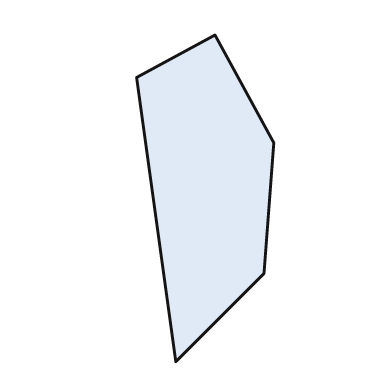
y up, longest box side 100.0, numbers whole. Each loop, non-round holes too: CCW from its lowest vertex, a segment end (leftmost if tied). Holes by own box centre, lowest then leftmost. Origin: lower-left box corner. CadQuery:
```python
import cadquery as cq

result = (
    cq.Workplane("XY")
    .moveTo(12.0, 0.0)
    .lineTo(39.0, 27.0)
    .lineTo(42.0, 67.0)
    .lineTo(24.0, 100.0)
    .lineTo(0.0, 87.0)
    .close()
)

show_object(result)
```